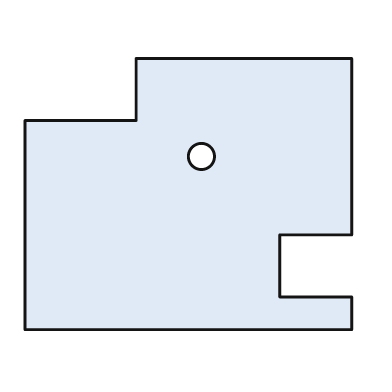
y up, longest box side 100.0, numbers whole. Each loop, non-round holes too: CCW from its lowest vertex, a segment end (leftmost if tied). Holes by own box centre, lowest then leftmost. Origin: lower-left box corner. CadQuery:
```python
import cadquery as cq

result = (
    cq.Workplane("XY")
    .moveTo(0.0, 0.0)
    .lineTo(100.0, 0.0)
    .lineTo(100.0, 10.0)
    .lineTo(78.0, 10.0)
    .lineTo(78.0, 29.0)
    .lineTo(100.0, 29.0)
    .lineTo(100.0, 83.0)
    .lineTo(34.0, 83.0)
    .lineTo(34.0, 64.0)
    .lineTo(0.0, 64.0)
    .close()
    .moveTo(54.0, 53.0)
    .circle(4.0)
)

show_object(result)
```